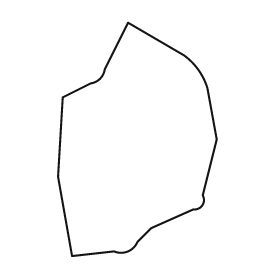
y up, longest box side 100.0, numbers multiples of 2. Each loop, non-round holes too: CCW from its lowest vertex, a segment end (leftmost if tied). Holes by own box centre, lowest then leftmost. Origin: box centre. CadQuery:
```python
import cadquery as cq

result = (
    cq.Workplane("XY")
    .moveTo(-28.0, -50.0)
    .lineTo(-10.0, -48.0)
    .threePointArc((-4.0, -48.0), (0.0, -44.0))
    .lineTo(6.0, -38.0)
    .lineTo(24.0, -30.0)
    .threePointArc((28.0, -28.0), (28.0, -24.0))
    .lineTo(34.0, 0.0)
    .lineTo(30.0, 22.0)
    .threePointArc((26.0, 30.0), (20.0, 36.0))
    .lineTo(-4.0, 50.0)
    .lineTo(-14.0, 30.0)
    .threePointArc((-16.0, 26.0), (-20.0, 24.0))
    .lineTo(-32.0, 18.0)
    .lineTo(-34.0, -16.0)
    .close()
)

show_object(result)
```